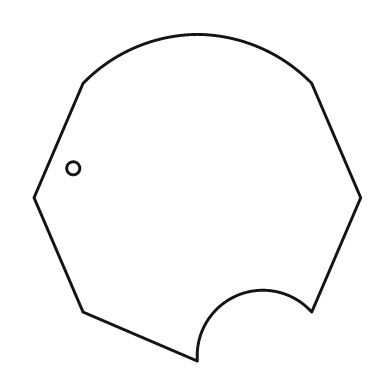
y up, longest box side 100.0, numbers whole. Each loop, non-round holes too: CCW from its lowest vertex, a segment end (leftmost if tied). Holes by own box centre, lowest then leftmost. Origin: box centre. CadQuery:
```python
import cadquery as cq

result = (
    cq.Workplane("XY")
    .moveTo(0.0, -50.0)
    .threePointArc((12.0, -30.0), (35.0, -35.0))
    .lineTo(50.0, 0.0)
    .lineTo(35.0, 35.0)
    .threePointArc((19.0, 46.0), (0.0, 50.0))
    .threePointArc((-19.0, 46.0), (-35.0, 35.0))
    .lineTo(-50.0, 0.0)
    .lineTo(-35.0, -35.0)
    .close()
    .moveTo(-38.0, 9.0)
    .circle(2.0)
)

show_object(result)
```